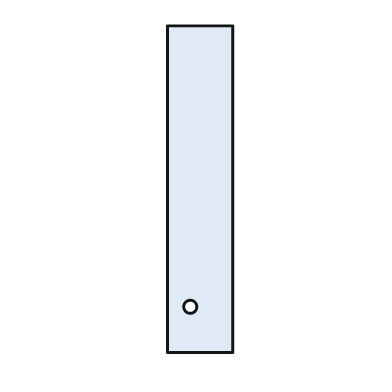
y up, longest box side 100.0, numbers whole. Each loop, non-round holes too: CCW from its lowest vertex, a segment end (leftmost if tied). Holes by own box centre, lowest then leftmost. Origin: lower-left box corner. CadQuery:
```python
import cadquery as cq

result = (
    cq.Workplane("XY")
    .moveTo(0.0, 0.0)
    .lineTo(20.0, 0.0)
    .lineTo(20.0, 100.0)
    .lineTo(0.0, 100.0)
    .close()
    .moveTo(7.0, 14.0)
    .circle(2.0)
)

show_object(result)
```